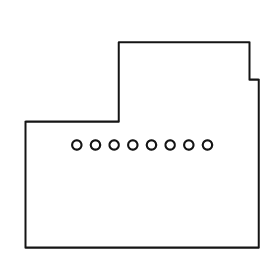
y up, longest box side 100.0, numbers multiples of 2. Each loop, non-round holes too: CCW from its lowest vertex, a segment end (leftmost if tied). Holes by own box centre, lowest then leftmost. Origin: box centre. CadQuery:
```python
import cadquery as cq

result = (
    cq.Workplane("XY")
    .moveTo(-50.0, -44.0)
    .lineTo(50.0, -44.0)
    .lineTo(50.0, 28.0)
    .lineTo(46.0, 28.0)
    .lineTo(46.0, 44.0)
    .lineTo(-10.0, 44.0)
    .lineTo(-10.0, 10.0)
    .lineTo(-50.0, 10.0)
    .close()
    .moveTo(-28.0, 0.0)
    .circle(2.0)
    .moveTo(-20.0, 0.0)
    .circle(2.0)
    .moveTo(-12.0, 0.0)
    .circle(2.0)
    .moveTo(-4.0, 0.0)
    .circle(2.0)
    .moveTo(4.0, 0.0)
    .circle(2.0)
    .moveTo(12.0, 0.0)
    .circle(2.0)
    .moveTo(20.0, 0.0)
    .circle(2.0)
    .moveTo(28.0, 0.0)
    .circle(2.0)
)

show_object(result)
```